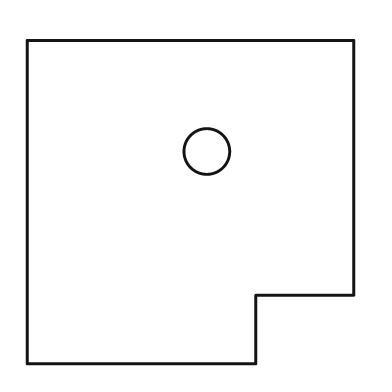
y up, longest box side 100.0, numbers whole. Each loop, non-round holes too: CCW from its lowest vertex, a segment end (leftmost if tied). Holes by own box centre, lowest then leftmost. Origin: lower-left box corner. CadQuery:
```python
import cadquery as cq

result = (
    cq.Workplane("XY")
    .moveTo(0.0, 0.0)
    .lineTo(70.0, 0.0)
    .lineTo(70.0, 21.0)
    .lineTo(100.0, 21.0)
    .lineTo(100.0, 99.0)
    .lineTo(0.0, 99.0)
    .close()
    .moveTo(55.0, 65.0)
    .circle(7.0)
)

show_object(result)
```